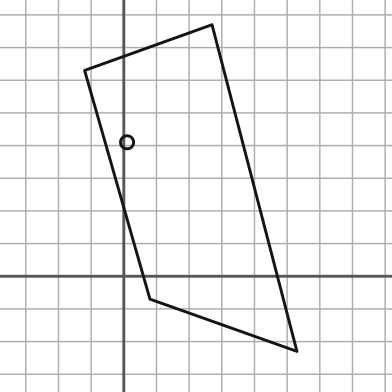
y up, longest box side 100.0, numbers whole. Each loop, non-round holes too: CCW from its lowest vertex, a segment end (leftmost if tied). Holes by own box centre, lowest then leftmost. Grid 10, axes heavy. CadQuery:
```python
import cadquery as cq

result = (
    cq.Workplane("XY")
    .moveTo(53.0, -23.0)
    .lineTo(27.0, 77.0)
    .lineTo(-12.0, 63.0)
    .lineTo(8.0, -7.0)
    .close()
    .moveTo(1.0, 41.0)
    .circle(2.0)
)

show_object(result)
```